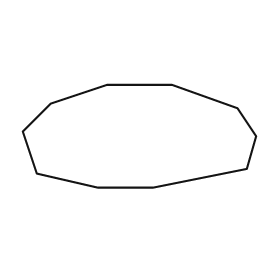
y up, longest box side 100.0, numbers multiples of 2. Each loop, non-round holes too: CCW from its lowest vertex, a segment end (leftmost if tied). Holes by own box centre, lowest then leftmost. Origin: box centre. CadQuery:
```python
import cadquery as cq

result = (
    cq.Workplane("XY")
    .moveTo(-18.0, -22.0)
    .lineTo(6.0, -22.0)
    .lineTo(46.0, -14.0)
    .lineTo(50.0, 0.0)
    .lineTo(42.0, 12.0)
    .lineTo(14.0, 22.0)
    .lineTo(-14.0, 22.0)
    .lineTo(-38.0, 14.0)
    .lineTo(-50.0, 2.0)
    .lineTo(-44.0, -16.0)
    .close()
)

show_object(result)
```